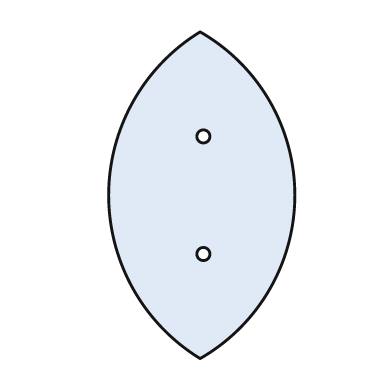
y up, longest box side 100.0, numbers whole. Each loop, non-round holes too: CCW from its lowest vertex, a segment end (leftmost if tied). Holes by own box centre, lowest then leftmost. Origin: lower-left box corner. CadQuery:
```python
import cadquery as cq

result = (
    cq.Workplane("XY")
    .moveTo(28.0, 0.0)
    .threePointArc((57.0, 50.0), (28.0, 100.0))
    .threePointArc((0.0, 50.0), (28.0, 0.0))
    .close()
    .moveTo(29.0, 32.0)
    .circle(2.0)
    .moveTo(29.0, 68.0)
    .circle(2.0)
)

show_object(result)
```